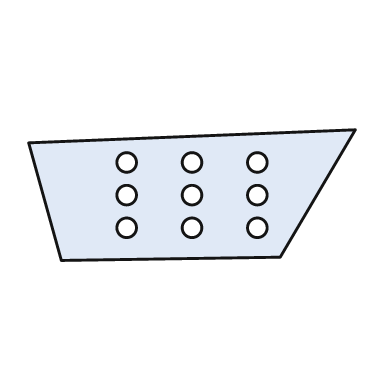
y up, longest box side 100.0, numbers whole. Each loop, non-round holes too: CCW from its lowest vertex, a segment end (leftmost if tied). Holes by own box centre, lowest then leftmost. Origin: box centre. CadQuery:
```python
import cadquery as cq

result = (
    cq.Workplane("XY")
    .moveTo(-40.0, -20.0)
    .lineTo(27.0, -19.0)
    .lineTo(50.0, 20.0)
    .lineTo(-50.0, 16.0)
    .close()
    .moveTo(-20.0, -10.0)
    .circle(3.0)
    .moveTo(0.0, -10.0)
    .circle(3.0)
    .moveTo(20.0, -10.0)
    .circle(3.0)
    .moveTo(-20.0, 0.0)
    .circle(3.0)
    .moveTo(0.0, 0.0)
    .circle(3.0)
    .moveTo(20.0, 0.0)
    .circle(3.0)
    .moveTo(-20.0, 10.0)
    .circle(3.0)
    .moveTo(0.0, 10.0)
    .circle(3.0)
    .moveTo(20.0, 10.0)
    .circle(3.0)
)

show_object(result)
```